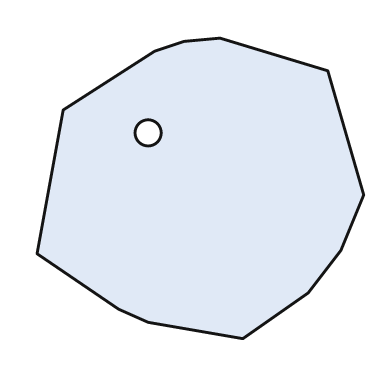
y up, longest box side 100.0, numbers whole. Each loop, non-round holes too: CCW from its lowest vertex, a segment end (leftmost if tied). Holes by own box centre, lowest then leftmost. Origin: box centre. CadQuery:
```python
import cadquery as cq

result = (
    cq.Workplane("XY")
    .moveTo(13.0, -46.0)
    .lineTo(33.0, -32.0)
    .lineTo(43.0, -19.0)
    .lineTo(50.0, -2.0)
    .lineTo(39.0, 36.0)
    .lineTo(6.0, 46.0)
    .lineTo(-5.0, 45.0)
    .lineTo(-14.0, 42.0)
    .lineTo(-42.0, 24.0)
    .lineTo(-50.0, -20.0)
    .lineTo(-25.0, -37.0)
    .lineTo(-16.0, -41.0)
    .close()
    .moveTo(-16.0, 17.0)
    .circle(4.0)
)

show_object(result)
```